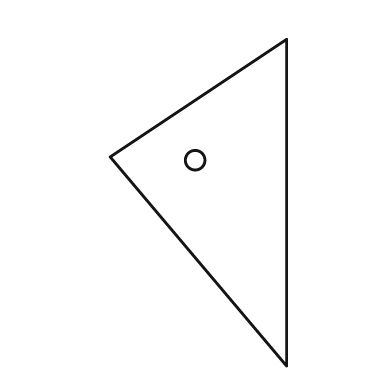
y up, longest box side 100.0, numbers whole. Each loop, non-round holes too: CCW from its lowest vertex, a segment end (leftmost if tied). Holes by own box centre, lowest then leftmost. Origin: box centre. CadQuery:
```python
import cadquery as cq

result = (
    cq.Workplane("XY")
    .moveTo(27.0, -50.0)
    .lineTo(27.0, 50.0)
    .lineTo(-27.0, 14.0)
    .close()
    .moveTo(-1.0, 13.0)
    .circle(3.0)
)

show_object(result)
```